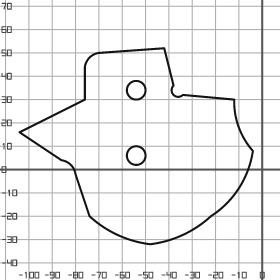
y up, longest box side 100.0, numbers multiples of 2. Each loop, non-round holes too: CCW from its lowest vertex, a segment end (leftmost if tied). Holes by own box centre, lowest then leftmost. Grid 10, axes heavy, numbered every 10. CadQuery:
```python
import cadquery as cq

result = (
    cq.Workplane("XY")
    .moveTo(-48.0, -32.0)
    .threePointArc((-34.0, -28.0), (-22.0, -20.0))
    .threePointArc((-10.0, -8.0), (-4.0, 8.0))
    .threePointArc((-10.0, 18.0), (-12.0, 30.0))
    .lineTo(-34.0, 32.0)
    .threePointArc((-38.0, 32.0), (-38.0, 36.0))
    .lineTo(-42.0, 52.0)
    .lineTo(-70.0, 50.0)
    .threePointArc((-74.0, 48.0), (-76.0, 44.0))
    .lineTo(-76.0, 30.0)
    .lineTo(-104.0, 16.0)
    .lineTo(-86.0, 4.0)
    .threePointArc((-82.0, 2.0), (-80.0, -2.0))
    .lineTo(-74.0, -20.0)
    .threePointArc((-62.0, -28.0), (-48.0, -32.0))
    .close()
    .moveTo(-54.0, 6.0)
    .circle(4.0)
    .moveTo(-54.0, 34.0)
    .circle(4.0)
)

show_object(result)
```